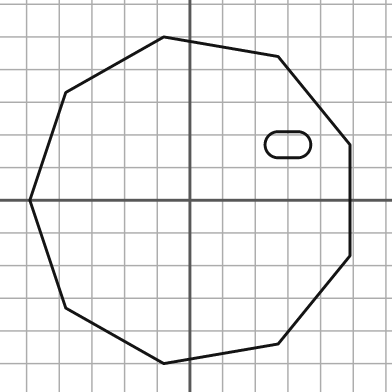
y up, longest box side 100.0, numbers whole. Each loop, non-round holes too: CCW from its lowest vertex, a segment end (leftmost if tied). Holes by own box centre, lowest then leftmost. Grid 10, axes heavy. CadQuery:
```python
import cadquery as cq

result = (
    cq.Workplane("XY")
    .moveTo(-8.0, -50.0)
    .lineTo(27.0, -44.0)
    .lineTo(49.0, -17.0)
    .lineTo(49.0, 17.0)
    .lineTo(27.0, 44.0)
    .lineTo(-8.0, 50.0)
    .lineTo(-38.0, 33.0)
    .lineTo(-49.0, 0.0)
    .lineTo(-38.0, -33.0)
    .close()
    .moveTo(27.0, 13.0)
    .lineTo(33.0, 13.0)
    .threePointArc((37.0, 17.0), (33.0, 21.0))
    .lineTo(27.0, 21.0)
    .threePointArc((23.0, 17.0), (27.0, 13.0))
    .close()
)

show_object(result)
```